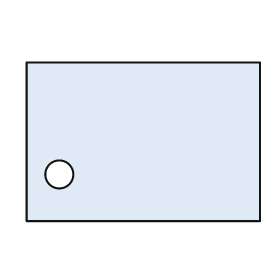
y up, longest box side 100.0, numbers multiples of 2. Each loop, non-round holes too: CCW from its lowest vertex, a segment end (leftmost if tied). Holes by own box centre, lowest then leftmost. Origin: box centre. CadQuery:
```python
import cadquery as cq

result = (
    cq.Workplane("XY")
    .moveTo(-50.0, -34.0)
    .lineTo(50.0, -34.0)
    .lineTo(50.0, 34.0)
    .lineTo(-50.0, 34.0)
    .close()
    .moveTo(-36.0, -14.0)
    .circle(6.0)
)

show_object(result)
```